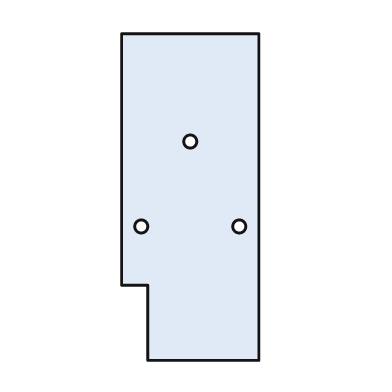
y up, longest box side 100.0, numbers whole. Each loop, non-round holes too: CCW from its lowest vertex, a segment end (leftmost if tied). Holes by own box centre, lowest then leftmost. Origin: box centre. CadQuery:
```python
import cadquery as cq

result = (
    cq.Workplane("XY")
    .moveTo(-13.0, -50.0)
    .lineTo(21.0, -50.0)
    .lineTo(21.0, 50.0)
    .lineTo(-21.0, 50.0)
    .lineTo(-21.0, -27.0)
    .lineTo(-13.0, -27.0)
    .close()
    .moveTo(-15.0, -9.0)
    .circle(2.0)
    .moveTo(15.0, -9.0)
    .circle(2.0)
    .moveTo(0.0, 17.0)
    .circle(2.0)
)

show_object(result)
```